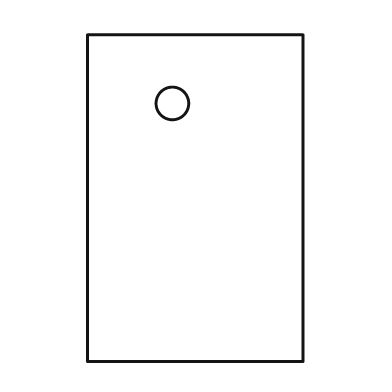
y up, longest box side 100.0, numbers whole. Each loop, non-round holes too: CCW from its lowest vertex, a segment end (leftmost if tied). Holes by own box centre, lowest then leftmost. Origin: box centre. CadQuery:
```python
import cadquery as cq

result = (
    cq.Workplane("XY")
    .moveTo(-33.0, -50.0)
    .lineTo(33.0, -50.0)
    .lineTo(33.0, 50.0)
    .lineTo(-33.0, 50.0)
    .close()
    .moveTo(-7.0, 29.0)
    .circle(5.0)
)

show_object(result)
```